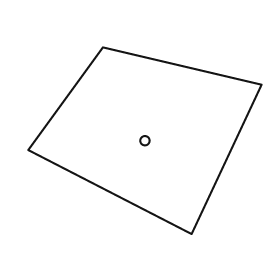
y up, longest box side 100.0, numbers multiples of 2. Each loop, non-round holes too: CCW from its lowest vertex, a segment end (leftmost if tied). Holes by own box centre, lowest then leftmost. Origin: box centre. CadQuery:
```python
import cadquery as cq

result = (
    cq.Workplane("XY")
    .moveTo(20.0, -40.0)
    .lineTo(50.0, 24.0)
    .lineTo(-18.0, 40.0)
    .lineTo(-50.0, -4.0)
    .close()
    .moveTo(0.0, 0.0)
    .circle(2.0)
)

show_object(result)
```